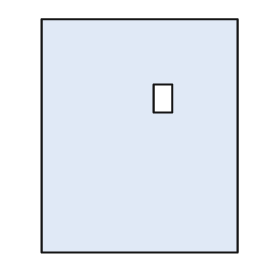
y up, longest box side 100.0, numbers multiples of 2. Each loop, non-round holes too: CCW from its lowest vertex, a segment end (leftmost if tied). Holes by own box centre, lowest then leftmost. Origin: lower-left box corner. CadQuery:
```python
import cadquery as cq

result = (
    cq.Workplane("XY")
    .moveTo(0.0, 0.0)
    .lineTo(84.0, 0.0)
    .lineTo(84.0, 100.0)
    .lineTo(0.0, 100.0)
    .close()
    .moveTo(48.0, 60.0)
    .lineTo(56.0, 60.0)
    .lineTo(56.0, 72.0)
    .lineTo(48.0, 72.0)
    .close()
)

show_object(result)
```